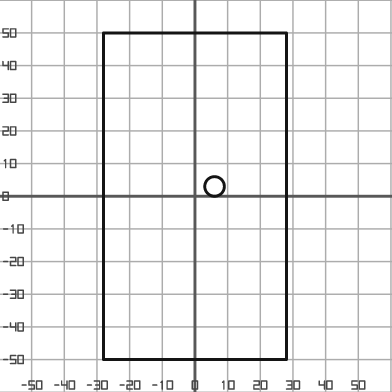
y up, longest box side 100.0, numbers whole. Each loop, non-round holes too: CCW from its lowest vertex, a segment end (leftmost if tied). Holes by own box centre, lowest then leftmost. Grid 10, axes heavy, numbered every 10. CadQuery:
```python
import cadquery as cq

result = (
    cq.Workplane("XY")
    .moveTo(-28.0, -50.0)
    .lineTo(28.0, -50.0)
    .lineTo(28.0, 50.0)
    .lineTo(-28.0, 50.0)
    .close()
    .moveTo(6.0, 3.0)
    .circle(3.0)
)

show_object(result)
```